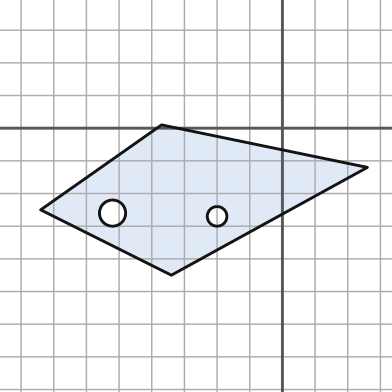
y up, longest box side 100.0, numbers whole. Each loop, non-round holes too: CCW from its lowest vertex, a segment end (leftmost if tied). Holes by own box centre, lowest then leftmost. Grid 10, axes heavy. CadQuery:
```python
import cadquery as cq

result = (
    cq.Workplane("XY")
    .moveTo(-34.0, -45.0)
    .lineTo(26.0, -12.0)
    .lineTo(-37.0, 1.0)
    .lineTo(-74.0, -25.0)
    .close()
    .moveTo(-20.0, -27.0)
    .circle(3.0)
    .moveTo(-52.0, -26.0)
    .circle(4.0)
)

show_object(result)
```